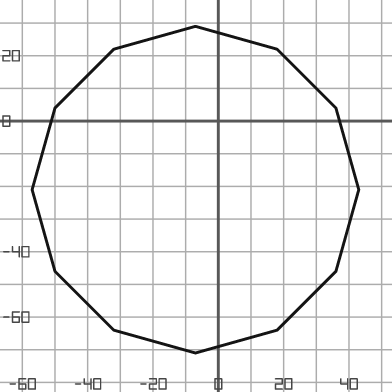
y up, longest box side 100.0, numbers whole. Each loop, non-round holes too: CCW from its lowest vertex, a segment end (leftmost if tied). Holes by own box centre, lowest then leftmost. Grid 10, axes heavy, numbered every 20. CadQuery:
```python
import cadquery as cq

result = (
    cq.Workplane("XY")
    .moveTo(-7.0, -71.0)
    .lineTo(18.0, -64.0)
    .lineTo(36.0, -46.0)
    .lineTo(43.0, -21.0)
    .lineTo(36.0, 4.0)
    .lineTo(18.0, 22.0)
    .lineTo(-7.0, 29.0)
    .lineTo(-32.0, 22.0)
    .lineTo(-50.0, 4.0)
    .lineTo(-57.0, -21.0)
    .lineTo(-50.0, -46.0)
    .lineTo(-32.0, -64.0)
    .close()
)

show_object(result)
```